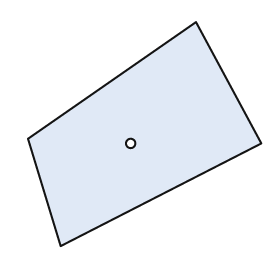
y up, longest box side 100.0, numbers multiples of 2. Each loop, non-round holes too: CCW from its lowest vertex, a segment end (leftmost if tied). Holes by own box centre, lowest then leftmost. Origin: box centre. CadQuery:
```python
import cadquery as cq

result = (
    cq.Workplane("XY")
    .moveTo(-36.0, -48.0)
    .lineTo(50.0, -4.0)
    .lineTo(22.0, 48.0)
    .lineTo(-50.0, -2.0)
    .close()
    .moveTo(-6.0, -4.0)
    .circle(2.0)
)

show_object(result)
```